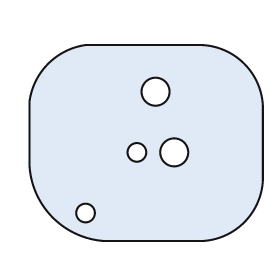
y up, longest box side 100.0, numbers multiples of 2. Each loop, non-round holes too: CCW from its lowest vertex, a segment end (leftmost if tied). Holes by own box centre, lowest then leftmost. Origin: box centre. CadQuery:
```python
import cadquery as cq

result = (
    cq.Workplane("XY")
    .moveTo(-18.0, -42.0)
    .lineTo(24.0, -42.0)
    .threePointArc((42.0, -34.0), (50.0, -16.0))
    .lineTo(50.0, 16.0)
    .threePointArc((42.0, 34.0), (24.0, 42.0))
    .lineTo(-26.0, 42.0)
    .threePointArc((-42.0, 34.0), (-50.0, 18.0))
    .lineTo(-50.0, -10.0)
    .threePointArc((-40.0, -32.0), (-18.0, -42.0))
    .close()
    .moveTo(-26.0, -30.0)
    .circle(4.0)
    .moveTo(-4.0, -4.0)
    .circle(4.0)
    .moveTo(12.0, -4.0)
    .circle(6.0)
    .moveTo(4.0, 22.0)
    .circle(6.0)
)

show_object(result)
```